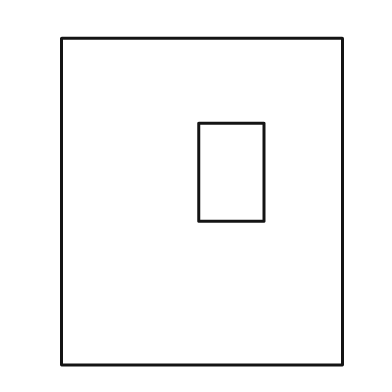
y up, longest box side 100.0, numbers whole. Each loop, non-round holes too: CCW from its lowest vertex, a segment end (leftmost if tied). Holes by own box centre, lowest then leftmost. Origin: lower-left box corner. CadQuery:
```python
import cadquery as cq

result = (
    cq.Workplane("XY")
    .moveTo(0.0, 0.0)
    .lineTo(86.0, 0.0)
    .lineTo(86.0, 100.0)
    .lineTo(0.0, 100.0)
    .close()
    .moveTo(42.0, 44.0)
    .lineTo(62.0, 44.0)
    .lineTo(62.0, 74.0)
    .lineTo(42.0, 74.0)
    .close()
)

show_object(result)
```